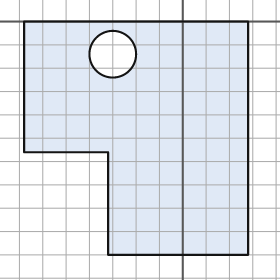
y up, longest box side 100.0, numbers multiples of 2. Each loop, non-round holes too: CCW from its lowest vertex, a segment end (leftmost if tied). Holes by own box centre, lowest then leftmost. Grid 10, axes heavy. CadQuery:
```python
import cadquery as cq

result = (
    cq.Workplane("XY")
    .moveTo(-32.0, -100.0)
    .lineTo(28.0, -100.0)
    .lineTo(28.0, 0.0)
    .lineTo(-68.0, 0.0)
    .lineTo(-68.0, -56.0)
    .lineTo(-32.0, -56.0)
    .close()
    .moveTo(-30.0, -14.0)
    .circle(10.0)
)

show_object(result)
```